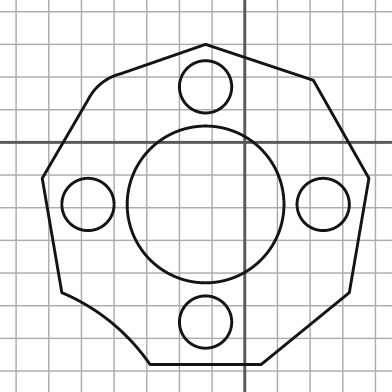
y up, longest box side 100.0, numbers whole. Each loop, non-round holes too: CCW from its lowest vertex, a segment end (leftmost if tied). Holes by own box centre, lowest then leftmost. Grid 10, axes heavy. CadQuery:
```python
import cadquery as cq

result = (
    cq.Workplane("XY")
    .moveTo(-29.0, -68.0)
    .lineTo(5.0, -68.0)
    .lineTo(32.0, -46.0)
    .lineTo(38.0, -11.0)
    .lineTo(21.0, 19.0)
    .lineTo(-12.0, 30.0)
    .lineTo(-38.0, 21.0)
    .threePointArc((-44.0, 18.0), (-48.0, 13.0))
    .lineTo(-62.0, -11.0)
    .lineTo(-56.0, -46.0)
    .threePointArc((-41.0, -55.0), (-29.0, -68.0))
    .close()
    .moveTo(-12.0, -55.0)
    .circle(8.0)
    .moveTo(-48.0, -19.0)
    .circle(8.0)
    .moveTo(-12.0, -19.0)
    .circle(24.0)
    .moveTo(24.0, -19.0)
    .circle(8.0)
    .moveTo(-12.0, 17.0)
    .circle(8.0)
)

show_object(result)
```